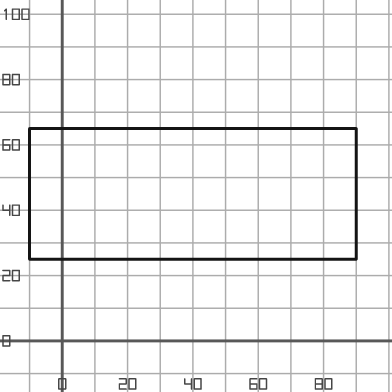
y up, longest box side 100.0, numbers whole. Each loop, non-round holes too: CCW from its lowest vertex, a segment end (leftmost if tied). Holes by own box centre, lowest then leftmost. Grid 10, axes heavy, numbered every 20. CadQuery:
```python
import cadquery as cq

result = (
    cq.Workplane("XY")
    .moveTo(-10.0, 25.0)
    .lineTo(90.0, 25.0)
    .lineTo(90.0, 65.0)
    .lineTo(-10.0, 65.0)
    .close()
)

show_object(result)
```